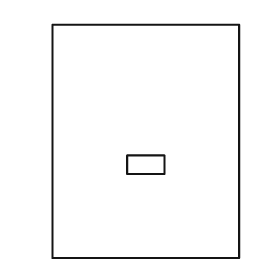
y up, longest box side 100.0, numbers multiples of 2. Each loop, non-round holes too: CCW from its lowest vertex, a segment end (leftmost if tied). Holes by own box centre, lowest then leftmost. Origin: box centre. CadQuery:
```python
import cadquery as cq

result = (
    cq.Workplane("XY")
    .moveTo(-40.0, -50.0)
    .lineTo(40.0, -50.0)
    .lineTo(40.0, 50.0)
    .lineTo(-40.0, 50.0)
    .close()
    .moveTo(-8.0, -14.0)
    .lineTo(8.0, -14.0)
    .lineTo(8.0, -6.0)
    .lineTo(-8.0, -6.0)
    .close()
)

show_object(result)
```